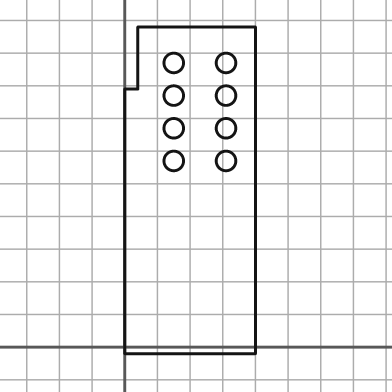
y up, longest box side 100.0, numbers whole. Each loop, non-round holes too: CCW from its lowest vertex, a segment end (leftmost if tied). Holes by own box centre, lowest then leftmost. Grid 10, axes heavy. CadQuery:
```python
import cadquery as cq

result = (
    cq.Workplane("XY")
    .moveTo(0.0, -2.0)
    .lineTo(40.0, -2.0)
    .lineTo(40.0, 98.0)
    .lineTo(4.0, 98.0)
    .lineTo(4.0, 79.0)
    .lineTo(0.0, 79.0)
    .close()
    .moveTo(15.0, 57.0)
    .circle(3.0)
    .moveTo(31.0, 57.0)
    .circle(3.0)
    .moveTo(15.0, 67.0)
    .circle(3.0)
    .moveTo(31.0, 67.0)
    .circle(3.0)
    .moveTo(15.0, 77.0)
    .circle(3.0)
    .moveTo(31.0, 77.0)
    .circle(3.0)
    .moveTo(15.0, 87.0)
    .circle(3.0)
    .moveTo(31.0, 87.0)
    .circle(3.0)
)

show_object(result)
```